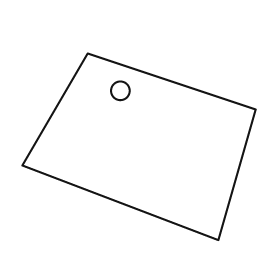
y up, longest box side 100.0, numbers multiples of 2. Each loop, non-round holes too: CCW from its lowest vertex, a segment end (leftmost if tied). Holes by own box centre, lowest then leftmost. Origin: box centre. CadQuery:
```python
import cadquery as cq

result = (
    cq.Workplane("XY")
    .moveTo(34.0, -40.0)
    .lineTo(50.0, 16.0)
    .lineTo(-22.0, 40.0)
    .lineTo(-50.0, -8.0)
    .close()
    .moveTo(-8.0, 24.0)
    .circle(4.0)
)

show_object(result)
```